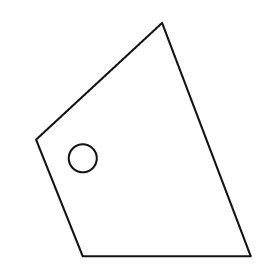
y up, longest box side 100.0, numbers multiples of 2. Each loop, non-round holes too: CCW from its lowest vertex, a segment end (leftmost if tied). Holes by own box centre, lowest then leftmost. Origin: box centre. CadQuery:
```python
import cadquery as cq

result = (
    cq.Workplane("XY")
    .moveTo(-26.0, -50.0)
    .lineTo(46.0, -50.0)
    .lineTo(8.0, 50.0)
    .lineTo(-46.0, 0.0)
    .close()
    .moveTo(-26.0, -8.0)
    .circle(6.0)
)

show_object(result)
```